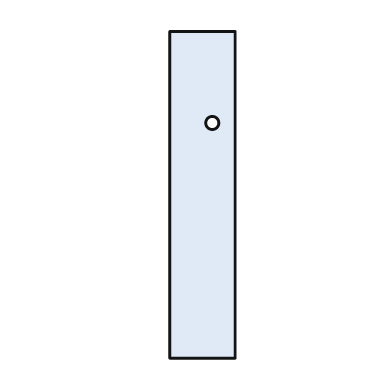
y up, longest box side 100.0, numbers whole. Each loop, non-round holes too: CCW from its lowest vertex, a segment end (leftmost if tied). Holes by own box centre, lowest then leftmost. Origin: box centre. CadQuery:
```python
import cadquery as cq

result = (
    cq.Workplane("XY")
    .moveTo(-10.0, -50.0)
    .lineTo(10.0, -50.0)
    .lineTo(10.0, 50.0)
    .lineTo(-10.0, 50.0)
    .close()
    .moveTo(3.0, 22.0)
    .circle(2.0)
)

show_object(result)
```